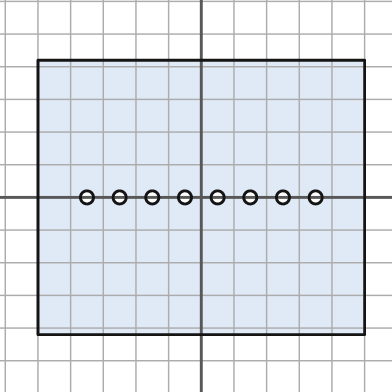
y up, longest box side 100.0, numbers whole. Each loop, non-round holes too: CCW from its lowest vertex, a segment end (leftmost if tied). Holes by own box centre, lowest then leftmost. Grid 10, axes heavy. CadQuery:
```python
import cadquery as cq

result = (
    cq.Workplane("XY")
    .moveTo(-50.0, -42.0)
    .lineTo(50.0, -42.0)
    .lineTo(50.0, 42.0)
    .lineTo(-50.0, 42.0)
    .close()
    .moveTo(-35.0, 0.0)
    .circle(2.0)
    .moveTo(-25.0, 0.0)
    .circle(2.0)
    .moveTo(-15.0, 0.0)
    .circle(2.0)
    .moveTo(-5.0, 0.0)
    .circle(2.0)
    .moveTo(5.0, 0.0)
    .circle(2.0)
    .moveTo(15.0, 0.0)
    .circle(2.0)
    .moveTo(25.0, 0.0)
    .circle(2.0)
    .moveTo(35.0, 0.0)
    .circle(2.0)
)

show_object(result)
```